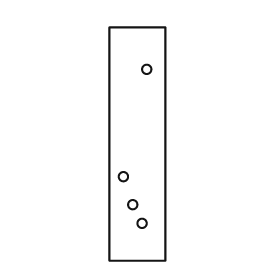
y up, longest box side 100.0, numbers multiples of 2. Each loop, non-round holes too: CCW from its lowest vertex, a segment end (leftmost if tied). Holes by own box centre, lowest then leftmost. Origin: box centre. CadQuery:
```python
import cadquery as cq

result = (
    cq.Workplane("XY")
    .moveTo(-12.0, -50.0)
    .lineTo(12.0, -50.0)
    .lineTo(12.0, 50.0)
    .lineTo(-12.0, 50.0)
    .close()
    .moveTo(2.0, -34.0)
    .circle(2.0)
    .moveTo(-2.0, -26.0)
    .circle(2.0)
    .moveTo(-6.0, -14.0)
    .circle(2.0)
    .moveTo(4.0, 32.0)
    .circle(2.0)
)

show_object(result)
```